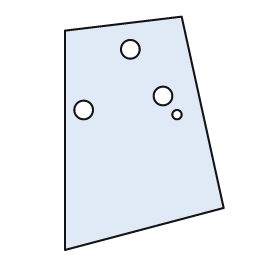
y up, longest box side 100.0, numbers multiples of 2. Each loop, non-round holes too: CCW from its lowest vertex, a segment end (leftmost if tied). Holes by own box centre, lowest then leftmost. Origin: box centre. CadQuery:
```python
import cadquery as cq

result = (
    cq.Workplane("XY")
    .moveTo(-34.0, -50.0)
    .lineTo(34.0, -32.0)
    .lineTo(16.0, 50.0)
    .lineTo(-34.0, 44.0)
    .close()
    .moveTo(14.0, 8.0)
    .circle(2.0)
    .moveTo(-26.0, 10.0)
    .circle(4.0)
    .moveTo(8.0, 16.0)
    .circle(4.0)
    .moveTo(-6.0, 36.0)
    .circle(4.0)
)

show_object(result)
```